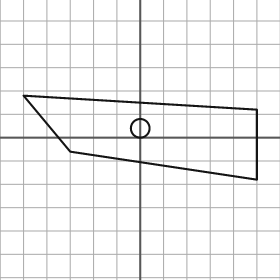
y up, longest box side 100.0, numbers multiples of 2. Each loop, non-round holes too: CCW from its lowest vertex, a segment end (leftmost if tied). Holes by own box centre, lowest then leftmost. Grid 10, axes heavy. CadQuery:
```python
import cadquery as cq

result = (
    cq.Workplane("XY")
    .moveTo(50.0, -18.0)
    .lineTo(50.0, 12.0)
    .lineTo(-50.0, 18.0)
    .lineTo(-30.0, -6.0)
    .close()
    .moveTo(0.0, 4.0)
    .circle(4.0)
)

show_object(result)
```